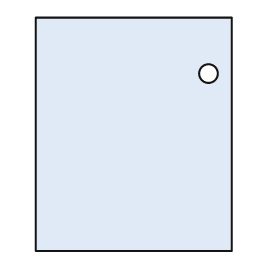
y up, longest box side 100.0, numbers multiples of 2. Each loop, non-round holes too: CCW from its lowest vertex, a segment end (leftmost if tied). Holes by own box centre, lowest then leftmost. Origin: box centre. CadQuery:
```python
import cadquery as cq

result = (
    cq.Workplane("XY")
    .moveTo(-42.0, -50.0)
    .lineTo(42.0, -50.0)
    .lineTo(42.0, 50.0)
    .lineTo(-42.0, 50.0)
    .close()
    .moveTo(32.0, 26.0)
    .circle(4.0)
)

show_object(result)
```